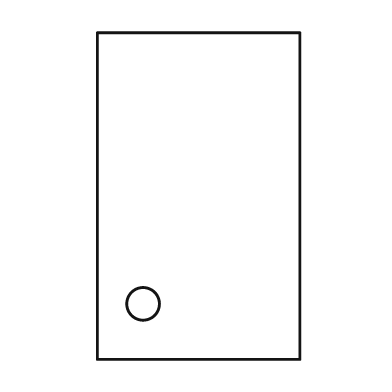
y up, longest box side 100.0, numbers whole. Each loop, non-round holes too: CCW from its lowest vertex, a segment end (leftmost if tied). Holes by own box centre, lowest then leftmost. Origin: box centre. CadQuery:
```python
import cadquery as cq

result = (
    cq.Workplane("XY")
    .moveTo(-31.0, -50.0)
    .lineTo(31.0, -50.0)
    .lineTo(31.0, 50.0)
    .lineTo(-31.0, 50.0)
    .close()
    .moveTo(-17.0, -33.0)
    .circle(5.0)
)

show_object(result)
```